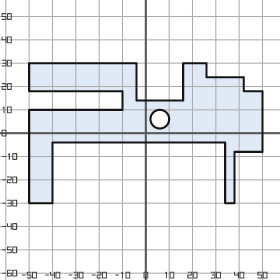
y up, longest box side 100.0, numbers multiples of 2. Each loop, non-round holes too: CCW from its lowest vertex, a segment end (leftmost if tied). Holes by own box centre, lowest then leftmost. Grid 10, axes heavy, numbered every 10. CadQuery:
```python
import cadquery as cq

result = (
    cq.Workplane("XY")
    .moveTo(-50.0, -30.0)
    .lineTo(-40.0, -30.0)
    .lineTo(-40.0, -4.0)
    .lineTo(34.0, -4.0)
    .lineTo(34.0, -30.0)
    .lineTo(38.0, -30.0)
    .lineTo(38.0, -8.0)
    .lineTo(50.0, -8.0)
    .lineTo(50.0, 18.0)
    .lineTo(42.0, 18.0)
    .lineTo(42.0, 24.0)
    .lineTo(26.0, 24.0)
    .lineTo(26.0, 30.0)
    .lineTo(16.0, 30.0)
    .lineTo(16.0, 14.0)
    .lineTo(-4.0, 14.0)
    .lineTo(-4.0, 30.0)
    .lineTo(-50.0, 30.0)
    .lineTo(-50.0, 18.0)
    .lineTo(-10.0, 18.0)
    .lineTo(-10.0, 10.0)
    .lineTo(-50.0, 10.0)
    .close()
    .moveTo(6.0, 6.0)
    .circle(4.0)
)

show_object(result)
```